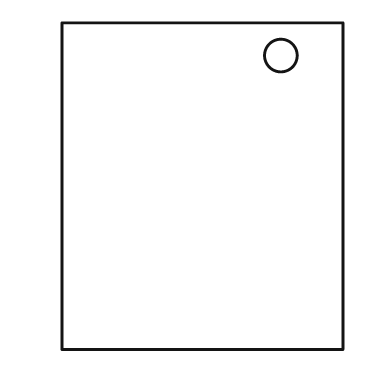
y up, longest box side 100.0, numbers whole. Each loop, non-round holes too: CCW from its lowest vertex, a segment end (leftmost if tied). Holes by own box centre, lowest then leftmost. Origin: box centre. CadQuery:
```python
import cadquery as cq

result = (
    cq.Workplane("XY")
    .moveTo(-43.0, -50.0)
    .lineTo(43.0, -50.0)
    .lineTo(43.0, 50.0)
    .lineTo(-43.0, 50.0)
    .close()
    .moveTo(24.0, 40.0)
    .circle(5.0)
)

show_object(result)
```